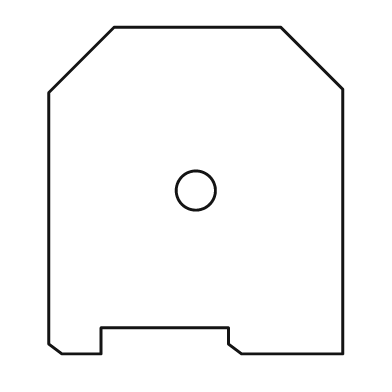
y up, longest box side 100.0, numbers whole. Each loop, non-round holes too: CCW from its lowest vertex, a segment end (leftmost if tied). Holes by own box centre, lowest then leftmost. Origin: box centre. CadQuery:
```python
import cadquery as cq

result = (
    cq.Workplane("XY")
    .moveTo(-41.0, -50.0)
    .lineTo(-29.0, -50.0)
    .lineTo(-29.0, -42.0)
    .lineTo(10.0, -42.0)
    .lineTo(10.0, -47.0)
    .lineTo(14.0, -50.0)
    .lineTo(45.0, -50.0)
    .lineTo(45.0, 31.0)
    .lineTo(26.0, 50.0)
    .lineTo(-25.0, 50.0)
    .lineTo(-45.0, 30.0)
    .lineTo(-45.0, -47.0)
    .close()
    .moveTo(0.0, 0.0)
    .circle(6.0)
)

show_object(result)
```